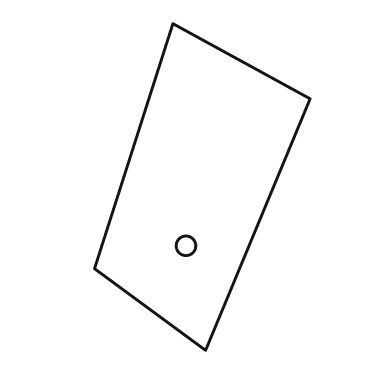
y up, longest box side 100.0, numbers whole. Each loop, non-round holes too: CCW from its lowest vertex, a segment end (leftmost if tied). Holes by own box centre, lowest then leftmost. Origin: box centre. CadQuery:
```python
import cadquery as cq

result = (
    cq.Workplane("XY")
    .moveTo(1.0, -50.0)
    .lineTo(33.0, 27.0)
    .lineTo(-9.0, 50.0)
    .lineTo(-33.0, -25.0)
    .close()
    .moveTo(-5.0, -18.0)
    .circle(3.0)
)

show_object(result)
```